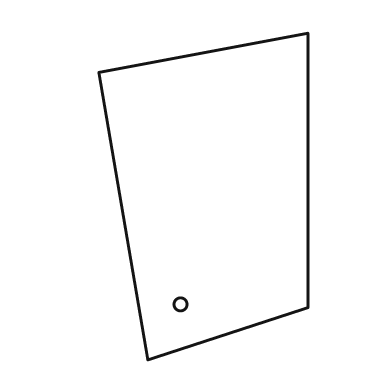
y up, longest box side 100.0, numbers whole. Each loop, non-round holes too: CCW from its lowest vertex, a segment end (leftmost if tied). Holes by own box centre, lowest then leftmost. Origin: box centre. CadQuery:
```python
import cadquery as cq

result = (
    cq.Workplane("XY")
    .moveTo(-17.0, -50.0)
    .lineTo(32.0, -34.0)
    .lineTo(32.0, 50.0)
    .lineTo(-32.0, 38.0)
    .close()
    .moveTo(-7.0, -33.0)
    .circle(2.0)
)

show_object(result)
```